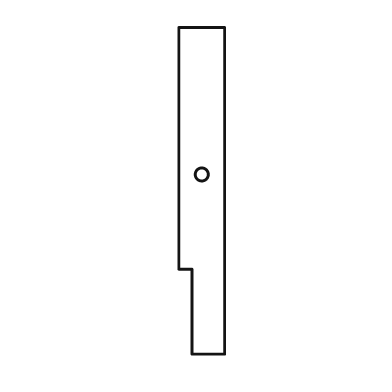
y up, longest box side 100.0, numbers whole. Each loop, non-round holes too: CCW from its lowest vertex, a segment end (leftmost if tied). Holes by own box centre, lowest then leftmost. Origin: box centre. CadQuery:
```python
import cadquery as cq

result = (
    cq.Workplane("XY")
    .moveTo(-3.0, -50.0)
    .lineTo(7.0, -50.0)
    .lineTo(7.0, 50.0)
    .lineTo(-7.0, 50.0)
    .lineTo(-7.0, -24.0)
    .lineTo(-3.0, -24.0)
    .close()
    .moveTo(0.0, 5.0)
    .circle(2.0)
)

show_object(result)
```